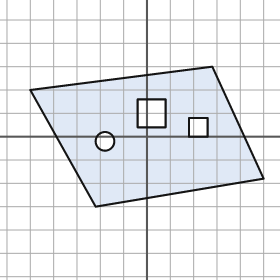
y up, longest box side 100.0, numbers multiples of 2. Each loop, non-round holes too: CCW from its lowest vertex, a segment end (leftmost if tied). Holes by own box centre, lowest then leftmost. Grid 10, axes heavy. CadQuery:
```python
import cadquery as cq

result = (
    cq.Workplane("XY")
    .moveTo(-22.0, -30.0)
    .lineTo(50.0, -18.0)
    .lineTo(28.0, 30.0)
    .lineTo(-50.0, 20.0)
    .close()
    .moveTo(-18.0, -2.0)
    .circle(4.0)
    .moveTo(18.0, 0.0)
    .lineTo(26.0, 0.0)
    .lineTo(26.0, 8.0)
    .lineTo(18.0, 8.0)
    .close()
    .moveTo(-4.0, 4.0)
    .lineTo(8.0, 4.0)
    .lineTo(8.0, 16.0)
    .lineTo(-4.0, 16.0)
    .close()
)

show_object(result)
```